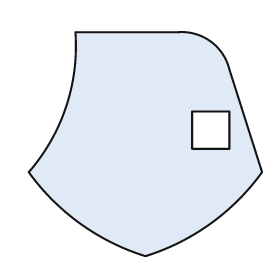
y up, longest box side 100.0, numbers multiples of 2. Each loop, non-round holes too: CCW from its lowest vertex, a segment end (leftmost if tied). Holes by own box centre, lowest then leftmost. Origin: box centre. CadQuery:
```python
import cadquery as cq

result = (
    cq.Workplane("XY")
    .moveTo(0.0, -48.0)
    .threePointArc((28.0, -34.0), (50.0, -12.0))
    .lineTo(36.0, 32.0)
    .threePointArc((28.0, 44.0), (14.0, 48.0))
    .lineTo(-30.0, 48.0)
    .threePointArc((-34.0, 16.0), (-50.0, -12.0))
    .threePointArc((-28.0, -34.0), (0.0, -48.0))
    .close()
    .moveTo(20.0, -2.0)
    .lineTo(36.0, -2.0)
    .lineTo(36.0, 14.0)
    .lineTo(20.0, 14.0)
    .close()
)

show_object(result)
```